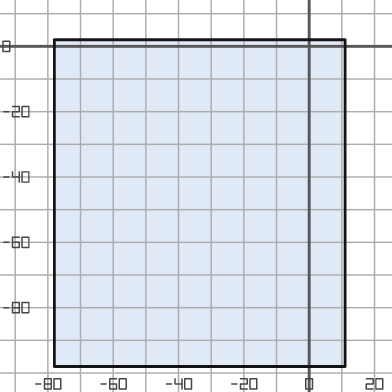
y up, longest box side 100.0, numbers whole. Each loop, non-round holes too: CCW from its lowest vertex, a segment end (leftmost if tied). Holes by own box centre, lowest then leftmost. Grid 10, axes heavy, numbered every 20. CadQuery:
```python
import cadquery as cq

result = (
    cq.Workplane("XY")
    .moveTo(-78.0, -98.0)
    .lineTo(11.0, -98.0)
    .lineTo(11.0, 2.0)
    .lineTo(-78.0, 2.0)
    .close()
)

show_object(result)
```